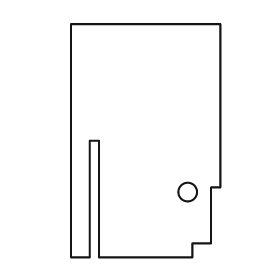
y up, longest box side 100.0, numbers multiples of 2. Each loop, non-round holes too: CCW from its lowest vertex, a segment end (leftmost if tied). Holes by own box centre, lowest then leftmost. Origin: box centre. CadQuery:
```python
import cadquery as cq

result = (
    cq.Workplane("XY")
    .moveTo(-32.0, -50.0)
    .lineTo(-24.0, -50.0)
    .lineTo(-24.0, 0.0)
    .lineTo(-20.0, 0.0)
    .lineTo(-20.0, -50.0)
    .lineTo(20.0, -50.0)
    .lineTo(20.0, -44.0)
    .lineTo(28.0, -44.0)
    .lineTo(28.0, -20.0)
    .lineTo(32.0, -20.0)
    .lineTo(32.0, 50.0)
    .lineTo(-32.0, 50.0)
    .close()
    .moveTo(18.0, -22.0)
    .circle(4.0)
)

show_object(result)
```